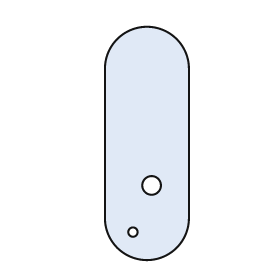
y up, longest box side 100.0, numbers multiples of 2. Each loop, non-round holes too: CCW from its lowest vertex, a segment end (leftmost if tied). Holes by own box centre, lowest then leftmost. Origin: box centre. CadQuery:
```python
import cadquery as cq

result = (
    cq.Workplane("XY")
    .moveTo(-18.0, -32.0)
    .threePointArc((0.0, -50.0), (18.0, -32.0))
    .lineTo(18.0, 32.0)
    .threePointArc((0.0, 50.0), (-18.0, 32.0))
    .close()
    .moveTo(-6.0, -38.0)
    .circle(2.0)
    .moveTo(2.0, -18.0)
    .circle(4.0)
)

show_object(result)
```